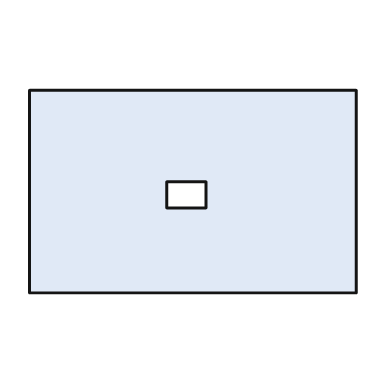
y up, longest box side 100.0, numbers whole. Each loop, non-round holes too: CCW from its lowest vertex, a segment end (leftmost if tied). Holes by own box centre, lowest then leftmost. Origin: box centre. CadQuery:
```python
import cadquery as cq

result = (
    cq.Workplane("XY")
    .moveTo(-50.0, -31.0)
    .lineTo(50.0, -31.0)
    .lineTo(50.0, 31.0)
    .lineTo(-50.0, 31.0)
    .close()
    .moveTo(-8.0, -5.0)
    .lineTo(4.0, -5.0)
    .lineTo(4.0, 3.0)
    .lineTo(-8.0, 3.0)
    .close()
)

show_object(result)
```